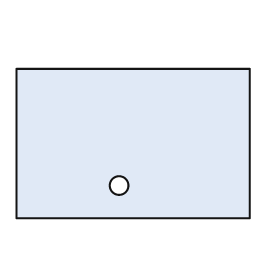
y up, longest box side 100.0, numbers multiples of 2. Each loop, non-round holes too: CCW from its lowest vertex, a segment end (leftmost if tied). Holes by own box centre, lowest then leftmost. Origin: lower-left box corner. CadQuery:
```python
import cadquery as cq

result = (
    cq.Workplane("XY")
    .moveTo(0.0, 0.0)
    .lineTo(100.0, 0.0)
    .lineTo(100.0, 64.0)
    .lineTo(0.0, 64.0)
    .close()
    .moveTo(44.0, 14.0)
    .circle(4.0)
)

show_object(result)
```